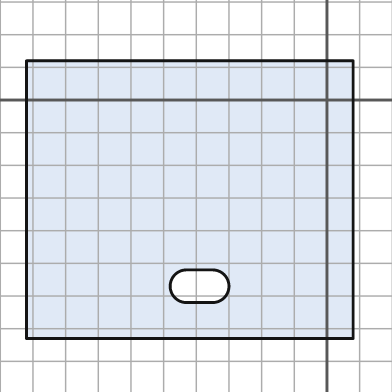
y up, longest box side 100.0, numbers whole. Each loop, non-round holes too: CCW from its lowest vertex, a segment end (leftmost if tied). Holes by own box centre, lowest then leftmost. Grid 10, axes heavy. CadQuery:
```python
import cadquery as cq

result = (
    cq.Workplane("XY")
    .moveTo(-92.0, -73.0)
    .lineTo(8.0, -73.0)
    .lineTo(8.0, 12.0)
    .lineTo(-92.0, 12.0)
    .close()
    .moveTo(-43.0, -62.0)
    .lineTo(-35.0, -62.0)
    .threePointArc((-30.0, -57.0), (-35.0, -52.0))
    .lineTo(-43.0, -52.0)
    .threePointArc((-48.0, -57.0), (-43.0, -62.0))
    .close()
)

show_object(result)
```